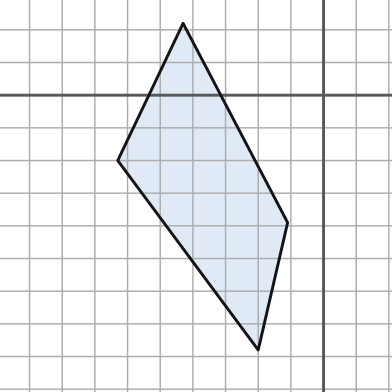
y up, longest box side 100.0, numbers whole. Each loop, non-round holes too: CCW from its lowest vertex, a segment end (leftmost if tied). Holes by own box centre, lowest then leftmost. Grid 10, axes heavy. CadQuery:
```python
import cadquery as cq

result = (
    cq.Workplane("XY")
    .moveTo(-20.0, -78.0)
    .lineTo(-11.0, -39.0)
    .lineTo(-43.0, 22.0)
    .lineTo(-63.0, -20.0)
    .close()
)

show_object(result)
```